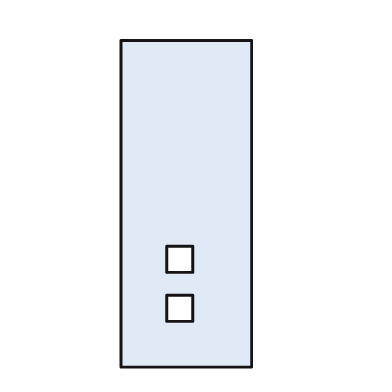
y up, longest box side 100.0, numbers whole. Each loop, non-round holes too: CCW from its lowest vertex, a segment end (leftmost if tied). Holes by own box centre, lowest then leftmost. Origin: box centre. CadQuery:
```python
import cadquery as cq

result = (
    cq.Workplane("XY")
    .moveTo(-20.0, -50.0)
    .lineTo(20.0, -50.0)
    .lineTo(20.0, 50.0)
    .lineTo(-20.0, 50.0)
    .close()
    .moveTo(-6.0, -36.0)
    .lineTo(2.0, -36.0)
    .lineTo(2.0, -28.0)
    .lineTo(-6.0, -28.0)
    .close()
    .moveTo(-6.0, -21.0)
    .lineTo(2.0, -21.0)
    .lineTo(2.0, -13.0)
    .lineTo(-6.0, -13.0)
    .close()
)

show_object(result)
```